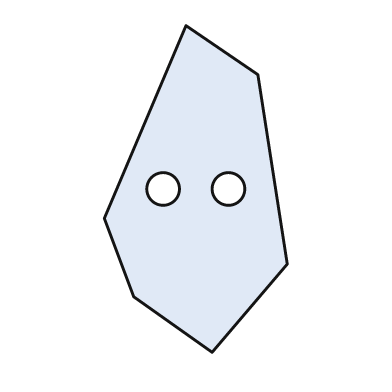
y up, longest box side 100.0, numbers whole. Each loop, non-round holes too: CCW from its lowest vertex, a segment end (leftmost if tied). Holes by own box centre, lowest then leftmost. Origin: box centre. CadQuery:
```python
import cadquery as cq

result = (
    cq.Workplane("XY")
    .moveTo(5.0, -50.0)
    .lineTo(28.0, -23.0)
    .lineTo(19.0, 35.0)
    .lineTo(-3.0, 50.0)
    .lineTo(-28.0, -9.0)
    .lineTo(-19.0, -33.0)
    .close()
    .moveTo(-10.0, 0.0)
    .circle(5.0)
    .moveTo(10.0, 0.0)
    .circle(5.0)
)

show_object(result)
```